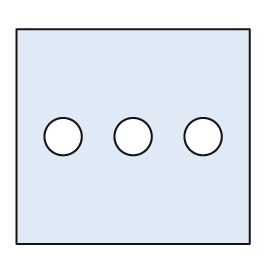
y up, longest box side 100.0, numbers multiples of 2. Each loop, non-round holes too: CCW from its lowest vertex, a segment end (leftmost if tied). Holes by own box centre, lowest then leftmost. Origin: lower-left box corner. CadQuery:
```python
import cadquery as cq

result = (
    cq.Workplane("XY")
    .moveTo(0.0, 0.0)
    .lineTo(100.0, 0.0)
    .lineTo(100.0, 92.0)
    .lineTo(0.0, 92.0)
    .close()
    .moveTo(20.0, 46.0)
    .circle(8.0)
    .moveTo(50.0, 46.0)
    .circle(8.0)
    .moveTo(80.0, 46.0)
    .circle(8.0)
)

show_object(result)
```